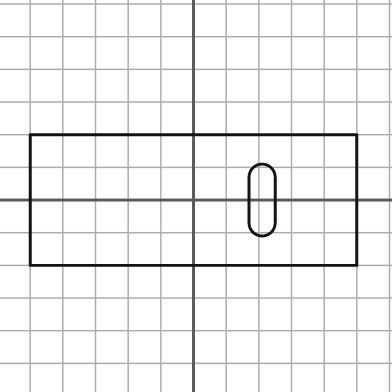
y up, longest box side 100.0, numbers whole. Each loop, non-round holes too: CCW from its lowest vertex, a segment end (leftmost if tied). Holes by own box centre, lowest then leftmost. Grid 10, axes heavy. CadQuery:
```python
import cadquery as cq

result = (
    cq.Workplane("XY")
    .moveTo(-50.0, -20.0)
    .lineTo(50.0, -20.0)
    .lineTo(50.0, 20.0)
    .lineTo(-50.0, 20.0)
    .close()
    .moveTo(17.0, -7.0)
    .threePointArc((21.0, -11.0), (25.0, -7.0))
    .lineTo(25.0, 7.0)
    .threePointArc((21.0, 11.0), (17.0, 7.0))
    .close()
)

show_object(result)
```